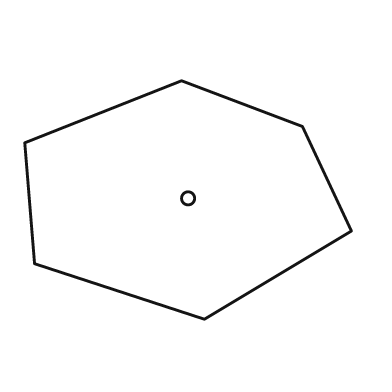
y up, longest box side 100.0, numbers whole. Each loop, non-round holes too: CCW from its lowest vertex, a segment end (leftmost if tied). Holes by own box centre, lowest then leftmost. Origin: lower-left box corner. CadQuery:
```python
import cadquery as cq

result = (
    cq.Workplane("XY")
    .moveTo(55.0, 0.0)
    .lineTo(100.0, 27.0)
    .lineTo(85.0, 59.0)
    .lineTo(48.0, 73.0)
    .lineTo(0.0, 54.0)
    .lineTo(3.0, 17.0)
    .close()
    .moveTo(50.0, 37.0)
    .circle(2.0)
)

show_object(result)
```